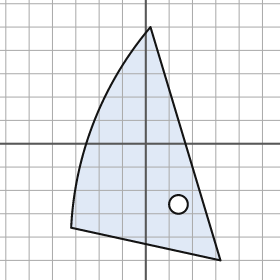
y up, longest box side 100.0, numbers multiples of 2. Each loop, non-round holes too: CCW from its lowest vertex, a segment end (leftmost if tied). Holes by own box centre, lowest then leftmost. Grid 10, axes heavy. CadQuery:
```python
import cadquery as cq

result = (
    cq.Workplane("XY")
    .moveTo(32.0, -50.0)
    .lineTo(2.0, 50.0)
    .threePointArc((-22.0, 10.0), (-32.0, -36.0))
    .close()
    .moveTo(14.0, -26.0)
    .circle(4.0)
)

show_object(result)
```